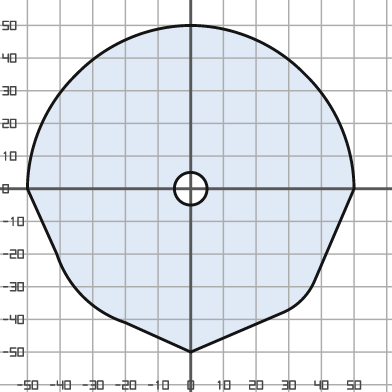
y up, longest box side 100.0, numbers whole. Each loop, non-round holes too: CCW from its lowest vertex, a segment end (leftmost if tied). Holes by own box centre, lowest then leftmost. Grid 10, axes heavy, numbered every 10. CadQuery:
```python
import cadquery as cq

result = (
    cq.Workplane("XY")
    .moveTo(0.0, -50.0)
    .lineTo(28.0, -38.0)
    .threePointArc((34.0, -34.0), (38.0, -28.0))
    .lineTo(50.0, 0.0)
    .threePointArc((46.0, 19.0), (35.0, 35.0))
    .threePointArc((19.0, 46.0), (0.0, 50.0))
    .threePointArc((-19.0, 46.0), (-35.0, 35.0))
    .threePointArc((-46.0, 19.0), (-50.0, 0.0))
    .lineTo(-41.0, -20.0)
    .threePointArc((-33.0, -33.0), (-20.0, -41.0))
    .close()
    .moveTo(0.0, 0.0)
    .circle(5.0)
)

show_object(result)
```